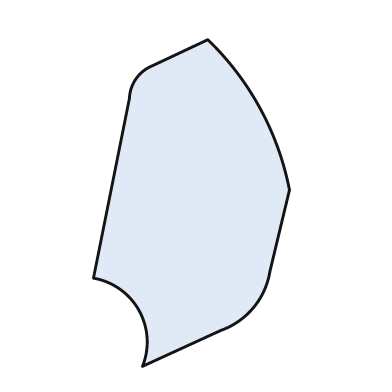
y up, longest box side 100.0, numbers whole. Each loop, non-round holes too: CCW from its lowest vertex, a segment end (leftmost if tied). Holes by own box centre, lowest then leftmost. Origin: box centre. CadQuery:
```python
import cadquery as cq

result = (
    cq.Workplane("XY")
    .moveTo(-15.0, -50.0)
    .lineTo(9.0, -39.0)
    .threePointArc((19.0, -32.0), (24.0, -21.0))
    .lineTo(30.0, 4.0)
    .threePointArc((21.0, 29.0), (5.0, 50.0))
    .lineTo(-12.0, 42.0)
    .threePointArc((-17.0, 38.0), (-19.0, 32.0))
    .lineTo(-30.0, -23.0)
    .threePointArc((-16.0, -33.0), (-15.0, -50.0))
    .close()
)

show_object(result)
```